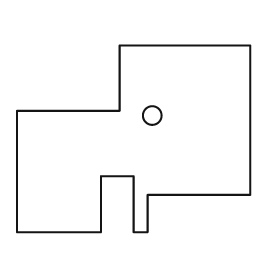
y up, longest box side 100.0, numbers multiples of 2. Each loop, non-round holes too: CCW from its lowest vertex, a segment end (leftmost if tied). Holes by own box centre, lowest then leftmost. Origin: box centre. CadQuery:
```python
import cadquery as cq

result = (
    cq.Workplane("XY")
    .moveTo(-50.0, -40.0)
    .lineTo(-14.0, -40.0)
    .lineTo(-14.0, -16.0)
    .lineTo(0.0, -16.0)
    .lineTo(0.0, -40.0)
    .lineTo(6.0, -40.0)
    .lineTo(6.0, -24.0)
    .lineTo(50.0, -24.0)
    .lineTo(50.0, 40.0)
    .lineTo(-6.0, 40.0)
    .lineTo(-6.0, 12.0)
    .lineTo(-50.0, 12.0)
    .close()
    .moveTo(8.0, 10.0)
    .circle(4.0)
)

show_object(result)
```